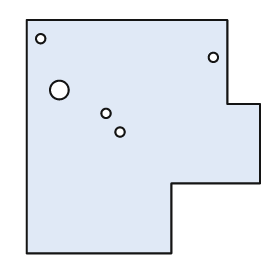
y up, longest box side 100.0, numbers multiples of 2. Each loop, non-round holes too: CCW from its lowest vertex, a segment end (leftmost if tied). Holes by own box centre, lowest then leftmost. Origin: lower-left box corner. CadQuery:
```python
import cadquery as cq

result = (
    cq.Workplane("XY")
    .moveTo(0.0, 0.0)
    .lineTo(62.0, 0.0)
    .lineTo(62.0, 30.0)
    .lineTo(100.0, 30.0)
    .lineTo(100.0, 64.0)
    .lineTo(86.0, 64.0)
    .lineTo(86.0, 100.0)
    .lineTo(0.0, 100.0)
    .close()
    .moveTo(40.0, 52.0)
    .circle(2.0)
    .moveTo(34.0, 60.0)
    .circle(2.0)
    .moveTo(14.0, 70.0)
    .circle(4.0)
    .moveTo(80.0, 84.0)
    .circle(2.0)
    .moveTo(6.0, 92.0)
    .circle(2.0)
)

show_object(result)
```